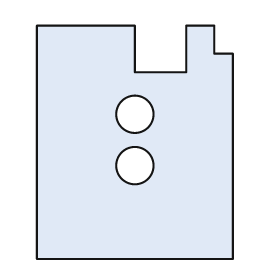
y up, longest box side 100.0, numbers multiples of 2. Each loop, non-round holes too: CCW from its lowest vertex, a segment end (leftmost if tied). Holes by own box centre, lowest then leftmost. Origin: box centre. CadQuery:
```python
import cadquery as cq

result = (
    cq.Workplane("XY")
    .moveTo(-42.0, -50.0)
    .lineTo(42.0, -50.0)
    .lineTo(42.0, 38.0)
    .lineTo(34.0, 38.0)
    .lineTo(34.0, 50.0)
    .lineTo(22.0, 50.0)
    .lineTo(22.0, 30.0)
    .lineTo(0.0, 30.0)
    .lineTo(0.0, 50.0)
    .lineTo(-42.0, 50.0)
    .close()
    .moveTo(0.0, -10.0)
    .circle(8.0)
    .moveTo(0.0, 12.0)
    .circle(8.0)
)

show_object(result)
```